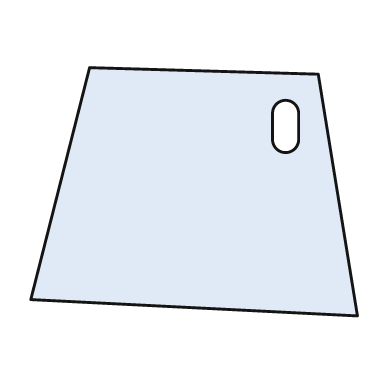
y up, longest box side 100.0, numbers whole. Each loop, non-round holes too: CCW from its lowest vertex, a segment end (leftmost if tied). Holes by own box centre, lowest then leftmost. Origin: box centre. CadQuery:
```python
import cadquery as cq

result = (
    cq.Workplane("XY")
    .moveTo(50.0, -38.0)
    .lineTo(38.0, 36.0)
    .lineTo(-32.0, 38.0)
    .lineTo(-50.0, -33.0)
    .close()
    .moveTo(24.0, 16.0)
    .threePointArc((28.0, 12.0), (32.0, 16.0))
    .lineTo(32.0, 24.0)
    .threePointArc((28.0, 28.0), (24.0, 24.0))
    .close()
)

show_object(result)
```